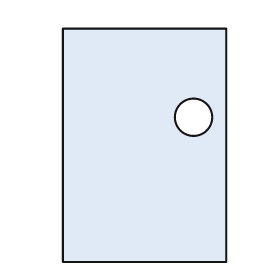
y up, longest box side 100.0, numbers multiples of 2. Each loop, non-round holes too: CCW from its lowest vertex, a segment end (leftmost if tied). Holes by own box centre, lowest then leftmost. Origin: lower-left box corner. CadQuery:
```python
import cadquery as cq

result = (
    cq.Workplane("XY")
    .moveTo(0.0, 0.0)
    .lineTo(70.0, 0.0)
    .lineTo(70.0, 100.0)
    .lineTo(0.0, 100.0)
    .close()
    .moveTo(56.0, 62.0)
    .circle(8.0)
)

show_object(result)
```